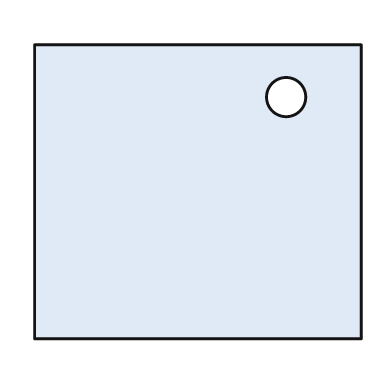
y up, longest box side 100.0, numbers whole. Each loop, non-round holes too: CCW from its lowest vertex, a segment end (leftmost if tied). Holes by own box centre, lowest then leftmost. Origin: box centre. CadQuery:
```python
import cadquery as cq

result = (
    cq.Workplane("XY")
    .moveTo(-50.0, -45.0)
    .lineTo(50.0, -45.0)
    .lineTo(50.0, 45.0)
    .lineTo(-50.0, 45.0)
    .close()
    .moveTo(27.0, 29.0)
    .circle(6.0)
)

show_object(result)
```